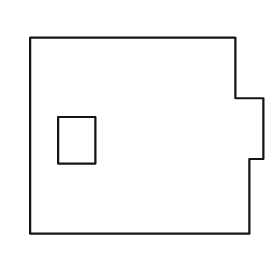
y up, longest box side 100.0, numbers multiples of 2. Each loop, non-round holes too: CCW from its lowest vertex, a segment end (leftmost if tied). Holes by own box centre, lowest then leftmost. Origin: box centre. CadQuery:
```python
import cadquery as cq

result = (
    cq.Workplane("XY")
    .moveTo(-50.0, -42.0)
    .lineTo(44.0, -42.0)
    .lineTo(44.0, -10.0)
    .lineTo(50.0, -10.0)
    .lineTo(50.0, 16.0)
    .lineTo(38.0, 16.0)
    .lineTo(38.0, 42.0)
    .lineTo(-50.0, 42.0)
    .close()
    .moveTo(-38.0, -12.0)
    .lineTo(-22.0, -12.0)
    .lineTo(-22.0, 8.0)
    .lineTo(-38.0, 8.0)
    .close()
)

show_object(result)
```